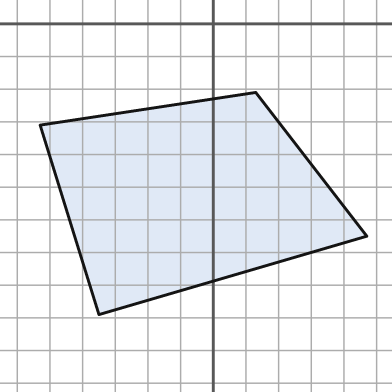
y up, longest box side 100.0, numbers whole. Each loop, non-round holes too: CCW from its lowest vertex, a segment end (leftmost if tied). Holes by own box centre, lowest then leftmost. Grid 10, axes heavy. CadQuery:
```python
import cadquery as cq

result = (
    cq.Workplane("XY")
    .moveTo(-35.0, -89.0)
    .lineTo(47.0, -65.0)
    .lineTo(13.0, -21.0)
    .lineTo(-53.0, -31.0)
    .close()
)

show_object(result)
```